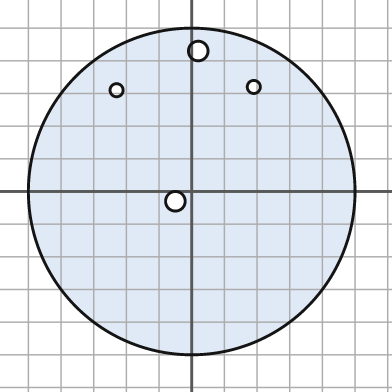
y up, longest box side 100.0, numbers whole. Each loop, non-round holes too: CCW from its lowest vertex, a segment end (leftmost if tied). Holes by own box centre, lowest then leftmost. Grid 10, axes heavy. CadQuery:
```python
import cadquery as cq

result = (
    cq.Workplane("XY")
    .moveTo(0.0, 0.0)
    .circle(50.0)
    .moveTo(-5.0, -3.0)
    .circle(3.0)
    .moveTo(-23.0, 31.0)
    .circle(2.0)
    .moveTo(19.0, 32.0)
    .circle(2.0)
    .moveTo(2.0, 43.0)
    .circle(3.0)
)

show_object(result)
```